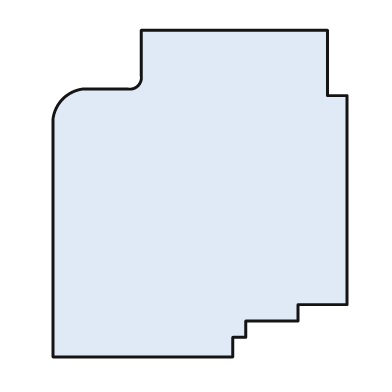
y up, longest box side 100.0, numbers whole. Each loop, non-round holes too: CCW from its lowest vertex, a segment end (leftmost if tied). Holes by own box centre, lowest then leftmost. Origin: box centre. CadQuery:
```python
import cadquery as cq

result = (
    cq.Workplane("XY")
    .moveTo(-45.0, -50.0)
    .lineTo(10.0, -50.0)
    .lineTo(10.0, -44.0)
    .lineTo(14.0, -44.0)
    .lineTo(14.0, -39.0)
    .lineTo(30.0, -39.0)
    .lineTo(30.0, -34.0)
    .lineTo(45.0, -34.0)
    .lineTo(45.0, 30.0)
    .lineTo(39.0, 30.0)
    .lineTo(39.0, 50.0)
    .lineTo(-18.0, 50.0)
    .lineTo(-18.0, 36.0)
    .threePointArc((-19.0, 33.0), (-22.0, 32.0))
    .lineTo(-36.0, 32.0)
    .threePointArc((-42.0, 29.0), (-45.0, 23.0))
    .close()
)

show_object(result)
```